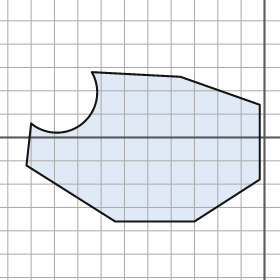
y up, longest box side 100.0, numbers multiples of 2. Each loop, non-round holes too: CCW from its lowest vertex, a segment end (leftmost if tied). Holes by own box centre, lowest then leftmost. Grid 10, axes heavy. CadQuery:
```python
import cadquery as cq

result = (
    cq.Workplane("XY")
    .moveTo(-64.0, -36.0)
    .lineTo(-30.0, -36.0)
    .lineTo(-2.0, -18.0)
    .lineTo(-2.0, 14.0)
    .lineTo(-36.0, 26.0)
    .lineTo(-74.0, 28.0)
    .threePointArc((-78.0, 6.0), (-100.0, 6.0))
    .lineTo(-102.0, -12.0)
    .close()
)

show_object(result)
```